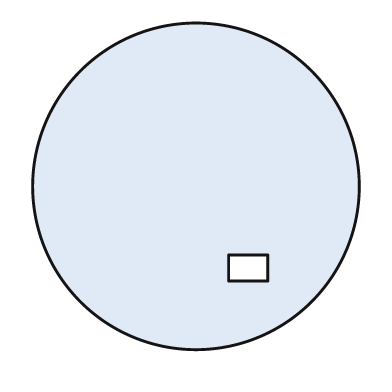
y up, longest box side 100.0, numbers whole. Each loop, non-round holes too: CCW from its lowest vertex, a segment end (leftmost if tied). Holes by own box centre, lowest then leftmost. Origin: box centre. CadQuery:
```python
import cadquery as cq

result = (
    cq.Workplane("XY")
    .moveTo(0.0, 0.0)
    .circle(50.0)
    .moveTo(10.0, -29.0)
    .lineTo(22.0, -29.0)
    .lineTo(22.0, -21.0)
    .lineTo(10.0, -21.0)
    .close()
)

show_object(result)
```